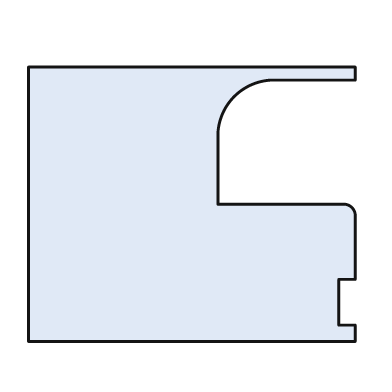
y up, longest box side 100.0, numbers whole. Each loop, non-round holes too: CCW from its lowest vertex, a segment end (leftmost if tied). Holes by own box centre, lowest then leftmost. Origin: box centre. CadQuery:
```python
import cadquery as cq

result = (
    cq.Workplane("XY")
    .moveTo(-50.0, -42.0)
    .lineTo(50.0, -42.0)
    .lineTo(50.0, -37.0)
    .lineTo(45.0, -37.0)
    .lineTo(45.0, -23.0)
    .lineTo(50.0, -23.0)
    .lineTo(50.0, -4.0)
    .threePointArc((49.0, -1.0), (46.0, 0.0))
    .lineTo(8.0, 0.0)
    .lineTo(8.0, 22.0)
    .threePointArc((13.0, 33.0), (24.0, 38.0))
    .lineTo(50.0, 38.0)
    .lineTo(50.0, 42.0)
    .lineTo(-50.0, 42.0)
    .close()
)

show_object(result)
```